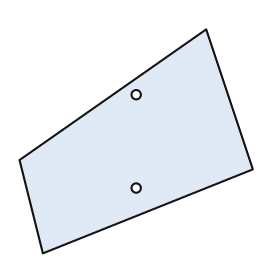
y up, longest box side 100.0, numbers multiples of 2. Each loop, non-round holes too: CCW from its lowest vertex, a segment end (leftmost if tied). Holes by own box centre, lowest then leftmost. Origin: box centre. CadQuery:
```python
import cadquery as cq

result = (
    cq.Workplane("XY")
    .moveTo(-40.0, -48.0)
    .lineTo(50.0, -12.0)
    .lineTo(30.0, 48.0)
    .lineTo(-50.0, -8.0)
    .close()
    .moveTo(0.0, -20.0)
    .circle(2.0)
    .moveTo(0.0, 20.0)
    .circle(2.0)
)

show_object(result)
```